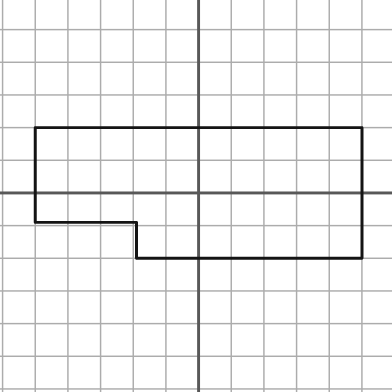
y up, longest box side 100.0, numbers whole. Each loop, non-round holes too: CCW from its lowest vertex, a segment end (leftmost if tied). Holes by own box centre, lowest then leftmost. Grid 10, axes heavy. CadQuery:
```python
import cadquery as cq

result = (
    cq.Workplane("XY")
    .moveTo(-19.0, -20.0)
    .lineTo(50.0, -20.0)
    .lineTo(50.0, 20.0)
    .lineTo(-50.0, 20.0)
    .lineTo(-50.0, -9.0)
    .lineTo(-19.0, -9.0)
    .close()
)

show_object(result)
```